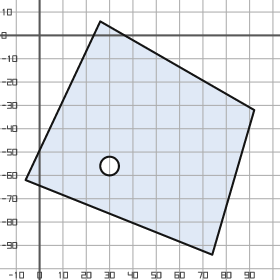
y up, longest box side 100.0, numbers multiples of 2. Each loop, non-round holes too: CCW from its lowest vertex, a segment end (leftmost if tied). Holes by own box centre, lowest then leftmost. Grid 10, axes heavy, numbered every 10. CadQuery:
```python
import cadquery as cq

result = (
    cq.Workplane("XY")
    .moveTo(74.0, -94.0)
    .lineTo(92.0, -32.0)
    .lineTo(26.0, 6.0)
    .lineTo(-6.0, -62.0)
    .close()
    .moveTo(30.0, -56.0)
    .circle(4.0)
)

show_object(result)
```